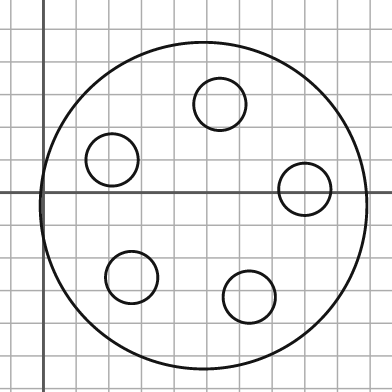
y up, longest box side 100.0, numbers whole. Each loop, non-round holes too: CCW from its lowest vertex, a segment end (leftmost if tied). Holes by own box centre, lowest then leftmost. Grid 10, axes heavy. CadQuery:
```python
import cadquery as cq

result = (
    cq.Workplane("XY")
    .moveTo(49.0, -4.0)
    .circle(50.0)
    .moveTo(63.0, -32.0)
    .circle(8.0)
    .moveTo(27.0, -26.0)
    .circle(8.0)
    .moveTo(80.0, 1.0)
    .circle(8.0)
    .moveTo(21.0, 10.0)
    .circle(8.0)
    .moveTo(54.0, 27.0)
    .circle(8.0)
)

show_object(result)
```